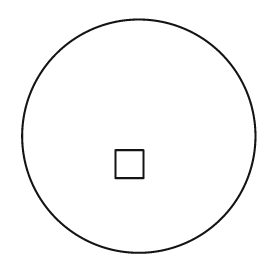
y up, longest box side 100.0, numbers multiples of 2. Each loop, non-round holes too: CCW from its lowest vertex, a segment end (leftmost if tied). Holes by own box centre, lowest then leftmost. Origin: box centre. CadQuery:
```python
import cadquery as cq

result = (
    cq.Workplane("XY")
    .moveTo(0.0, 0.0)
    .circle(50.0)
    .moveTo(-10.0, -18.0)
    .lineTo(2.0, -18.0)
    .lineTo(2.0, -6.0)
    .lineTo(-10.0, -6.0)
    .close()
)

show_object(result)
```